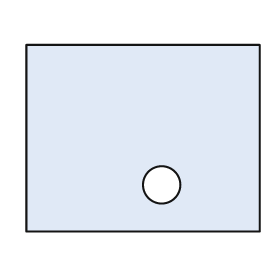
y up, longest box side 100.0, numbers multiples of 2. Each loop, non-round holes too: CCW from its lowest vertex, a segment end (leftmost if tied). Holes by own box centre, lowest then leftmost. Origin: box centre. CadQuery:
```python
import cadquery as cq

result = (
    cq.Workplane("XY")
    .moveTo(-50.0, -40.0)
    .lineTo(50.0, -40.0)
    .lineTo(50.0, 40.0)
    .lineTo(-50.0, 40.0)
    .close()
    .moveTo(8.0, -20.0)
    .circle(8.0)
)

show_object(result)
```